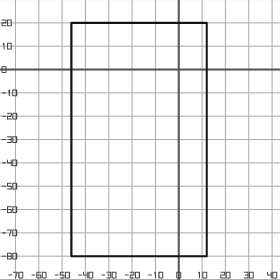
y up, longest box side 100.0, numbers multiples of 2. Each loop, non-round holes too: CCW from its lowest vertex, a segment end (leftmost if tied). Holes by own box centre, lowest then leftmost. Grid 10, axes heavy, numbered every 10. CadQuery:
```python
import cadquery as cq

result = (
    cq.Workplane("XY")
    .moveTo(-46.0, -80.0)
    .lineTo(12.0, -80.0)
    .lineTo(12.0, 20.0)
    .lineTo(-46.0, 20.0)
    .close()
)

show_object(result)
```